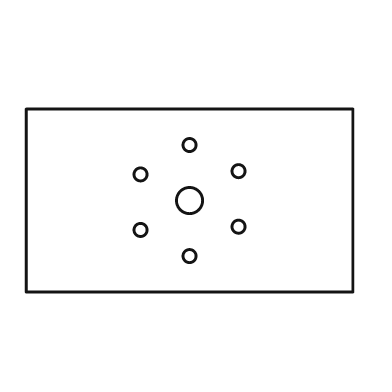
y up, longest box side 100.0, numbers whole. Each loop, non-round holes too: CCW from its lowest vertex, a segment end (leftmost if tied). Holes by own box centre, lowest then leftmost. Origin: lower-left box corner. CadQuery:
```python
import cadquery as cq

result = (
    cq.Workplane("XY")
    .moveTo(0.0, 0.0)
    .lineTo(100.0, 0.0)
    .lineTo(100.0, 56.0)
    .lineTo(0.0, 56.0)
    .close()
    .moveTo(50.0, 11.0)
    .circle(2.0)
    .moveTo(35.0, 19.0)
    .circle(2.0)
    .moveTo(65.0, 20.0)
    .circle(2.0)
    .moveTo(50.0, 28.0)
    .circle(4.0)
    .moveTo(35.0, 36.0)
    .circle(2.0)
    .moveTo(65.0, 37.0)
    .circle(2.0)
    .moveTo(50.0, 45.0)
    .circle(2.0)
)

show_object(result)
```